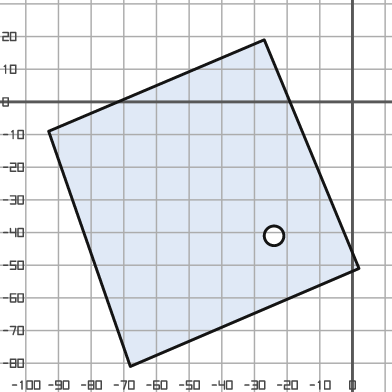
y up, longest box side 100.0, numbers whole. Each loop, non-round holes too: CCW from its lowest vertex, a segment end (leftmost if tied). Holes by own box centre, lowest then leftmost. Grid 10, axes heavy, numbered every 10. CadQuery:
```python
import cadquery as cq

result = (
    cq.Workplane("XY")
    .moveTo(-68.0, -81.0)
    .lineTo(2.0, -51.0)
    .lineTo(-27.0, 19.0)
    .lineTo(-93.0, -9.0)
    .close()
    .moveTo(-24.0, -41.0)
    .circle(3.0)
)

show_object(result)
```